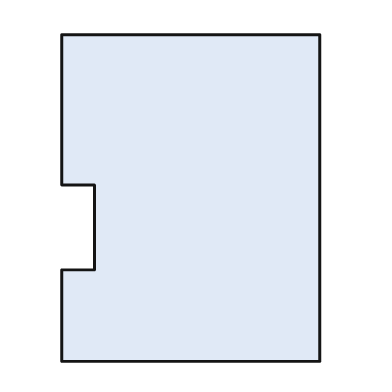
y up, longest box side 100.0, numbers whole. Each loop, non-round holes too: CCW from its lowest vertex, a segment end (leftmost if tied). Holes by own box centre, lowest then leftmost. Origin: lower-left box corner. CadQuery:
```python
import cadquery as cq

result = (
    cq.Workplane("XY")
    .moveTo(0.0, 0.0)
    .lineTo(79.0, 0.0)
    .lineTo(79.0, 100.0)
    .lineTo(0.0, 100.0)
    .lineTo(0.0, 54.0)
    .lineTo(10.0, 54.0)
    .lineTo(10.0, 28.0)
    .lineTo(0.0, 28.0)
    .close()
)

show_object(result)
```